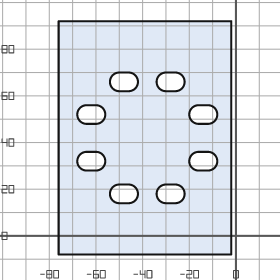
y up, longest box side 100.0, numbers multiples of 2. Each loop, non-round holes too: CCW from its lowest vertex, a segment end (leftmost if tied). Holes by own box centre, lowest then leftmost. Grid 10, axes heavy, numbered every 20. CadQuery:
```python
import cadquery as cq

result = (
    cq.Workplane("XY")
    .moveTo(-76.0, -8.0)
    .lineTo(-2.0, -8.0)
    .lineTo(-2.0, 92.0)
    .lineTo(-76.0, 92.0)
    .close()
    .moveTo(-50.0, 14.0)
    .lineTo(-46.0, 14.0)
    .threePointArc((-42.0, 18.0), (-46.0, 22.0))
    .lineTo(-50.0, 22.0)
    .threePointArc((-54.0, 18.0), (-50.0, 14.0))
    .close()
    .moveTo(-30.0, 14.0)
    .lineTo(-26.0, 14.0)
    .threePointArc((-22.0, 18.0), (-26.0, 22.0))
    .lineTo(-30.0, 22.0)
    .threePointArc((-34.0, 18.0), (-30.0, 14.0))
    .close()
    .moveTo(-64.0, 28.0)
    .lineTo(-60.0, 28.0)
    .threePointArc((-56.0, 32.0), (-60.0, 36.0))
    .lineTo(-64.0, 36.0)
    .threePointArc((-68.0, 32.0), (-64.0, 28.0))
    .close()
    .moveTo(-16.0, 28.0)
    .lineTo(-12.0, 28.0)
    .threePointArc((-8.0, 32.0), (-12.0, 36.0))
    .lineTo(-16.0, 36.0)
    .threePointArc((-20.0, 32.0), (-16.0, 28.0))
    .close()
    .moveTo(-64.0, 48.0)
    .lineTo(-60.0, 48.0)
    .threePointArc((-56.0, 52.0), (-60.0, 56.0))
    .lineTo(-64.0, 56.0)
    .threePointArc((-68.0, 52.0), (-64.0, 48.0))
    .close()
    .moveTo(-16.0, 48.0)
    .lineTo(-12.0, 48.0)
    .threePointArc((-8.0, 52.0), (-12.0, 56.0))
    .lineTo(-16.0, 56.0)
    .threePointArc((-20.0, 52.0), (-16.0, 48.0))
    .close()
    .moveTo(-50.0, 62.0)
    .lineTo(-46.0, 62.0)
    .threePointArc((-42.0, 66.0), (-46.0, 70.0))
    .lineTo(-50.0, 70.0)
    .threePointArc((-54.0, 66.0), (-50.0, 62.0))
    .close()
    .moveTo(-30.0, 62.0)
    .lineTo(-26.0, 62.0)
    .threePointArc((-22.0, 66.0), (-26.0, 70.0))
    .lineTo(-30.0, 70.0)
    .threePointArc((-34.0, 66.0), (-30.0, 62.0))
    .close()
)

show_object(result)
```